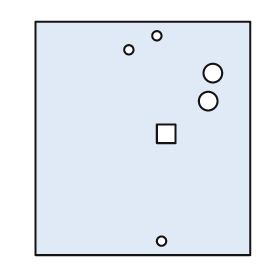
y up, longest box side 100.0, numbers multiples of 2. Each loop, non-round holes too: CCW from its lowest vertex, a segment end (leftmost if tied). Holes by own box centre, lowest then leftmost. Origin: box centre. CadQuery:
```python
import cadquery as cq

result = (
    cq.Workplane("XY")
    .moveTo(-46.0, -50.0)
    .lineTo(46.0, -50.0)
    .lineTo(46.0, 50.0)
    .lineTo(-46.0, 50.0)
    .close()
    .moveTo(8.0, -44.0)
    .circle(2.0)
    .moveTo(6.0, -2.0)
    .lineTo(14.0, -2.0)
    .lineTo(14.0, 6.0)
    .lineTo(6.0, 6.0)
    .close()
    .moveTo(28.0, 16.0)
    .circle(4.0)
    .moveTo(30.0, 28.0)
    .circle(4.0)
    .moveTo(-6.0, 38.0)
    .circle(2.0)
    .moveTo(6.0, 44.0)
    .circle(2.0)
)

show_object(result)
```